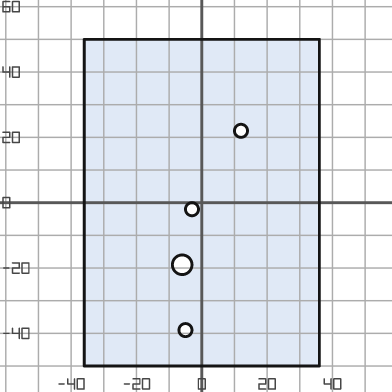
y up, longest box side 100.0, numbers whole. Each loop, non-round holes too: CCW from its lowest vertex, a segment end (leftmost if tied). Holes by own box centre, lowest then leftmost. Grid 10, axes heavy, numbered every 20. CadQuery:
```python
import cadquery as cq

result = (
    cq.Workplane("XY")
    .moveTo(-36.0, -50.0)
    .lineTo(36.0, -50.0)
    .lineTo(36.0, 50.0)
    .lineTo(-36.0, 50.0)
    .close()
    .moveTo(-5.0, -39.0)
    .circle(2.0)
    .moveTo(-6.0, -19.0)
    .circle(3.0)
    .moveTo(-3.0, -2.0)
    .circle(2.0)
    .moveTo(12.0, 22.0)
    .circle(2.0)
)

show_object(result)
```